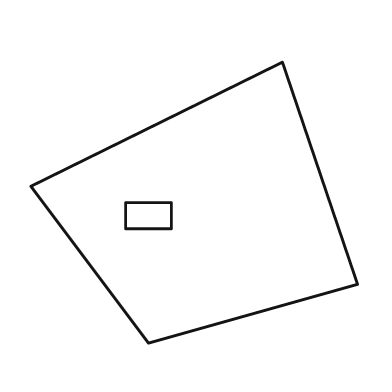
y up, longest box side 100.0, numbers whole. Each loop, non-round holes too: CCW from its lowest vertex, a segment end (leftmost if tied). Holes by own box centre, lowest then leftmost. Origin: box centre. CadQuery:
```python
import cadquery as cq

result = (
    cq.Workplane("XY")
    .moveTo(-14.0, -43.0)
    .lineTo(50.0, -25.0)
    .lineTo(27.0, 43.0)
    .lineTo(-50.0, 5.0)
    .close()
    .moveTo(-21.0, -8.0)
    .lineTo(-7.0, -8.0)
    .lineTo(-7.0, 0.0)
    .lineTo(-21.0, 0.0)
    .close()
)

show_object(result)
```